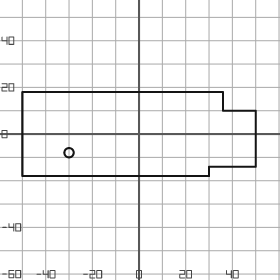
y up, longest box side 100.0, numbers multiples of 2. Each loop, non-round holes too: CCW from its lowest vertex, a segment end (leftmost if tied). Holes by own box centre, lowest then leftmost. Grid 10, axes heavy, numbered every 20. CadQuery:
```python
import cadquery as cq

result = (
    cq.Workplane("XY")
    .moveTo(-50.0, -18.0)
    .lineTo(30.0, -18.0)
    .lineTo(30.0, -14.0)
    .lineTo(50.0, -14.0)
    .lineTo(50.0, 10.0)
    .lineTo(36.0, 10.0)
    .lineTo(36.0, 18.0)
    .lineTo(-50.0, 18.0)
    .close()
    .moveTo(-30.0, -8.0)
    .circle(2.0)
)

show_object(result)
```